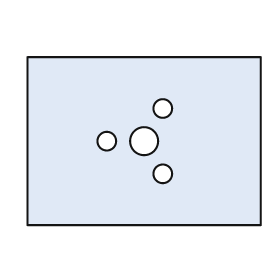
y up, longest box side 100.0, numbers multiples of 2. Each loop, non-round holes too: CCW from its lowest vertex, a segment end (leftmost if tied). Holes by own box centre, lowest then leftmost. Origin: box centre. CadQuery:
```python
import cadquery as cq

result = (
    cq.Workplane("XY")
    .moveTo(-50.0, -36.0)
    .lineTo(50.0, -36.0)
    .lineTo(50.0, 36.0)
    .lineTo(-50.0, 36.0)
    .close()
    .moveTo(8.0, -14.0)
    .circle(4.0)
    .moveTo(-16.0, 0.0)
    .circle(4.0)
    .moveTo(0.0, 0.0)
    .circle(6.0)
    .moveTo(8.0, 14.0)
    .circle(4.0)
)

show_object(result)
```